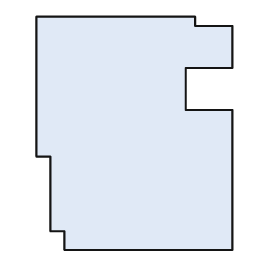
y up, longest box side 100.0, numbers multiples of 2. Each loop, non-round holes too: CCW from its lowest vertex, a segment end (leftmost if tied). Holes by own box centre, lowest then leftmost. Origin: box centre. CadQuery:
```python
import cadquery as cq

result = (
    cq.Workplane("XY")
    .moveTo(-30.0, -50.0)
    .lineTo(42.0, -50.0)
    .lineTo(42.0, 10.0)
    .lineTo(22.0, 10.0)
    .lineTo(22.0, 28.0)
    .lineTo(42.0, 28.0)
    .lineTo(42.0, 46.0)
    .lineTo(26.0, 46.0)
    .lineTo(26.0, 50.0)
    .lineTo(-42.0, 50.0)
    .lineTo(-42.0, -10.0)
    .lineTo(-36.0, -10.0)
    .lineTo(-36.0, -42.0)
    .lineTo(-30.0, -42.0)
    .close()
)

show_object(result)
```